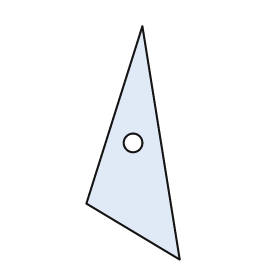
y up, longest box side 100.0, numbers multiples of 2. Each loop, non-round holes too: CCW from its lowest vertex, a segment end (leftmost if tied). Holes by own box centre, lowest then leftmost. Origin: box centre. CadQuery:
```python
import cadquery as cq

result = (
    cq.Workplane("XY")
    .moveTo(20.0, -50.0)
    .lineTo(4.0, 50.0)
    .lineTo(-20.0, -26.0)
    .close()
    .moveTo(0.0, 0.0)
    .circle(4.0)
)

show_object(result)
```